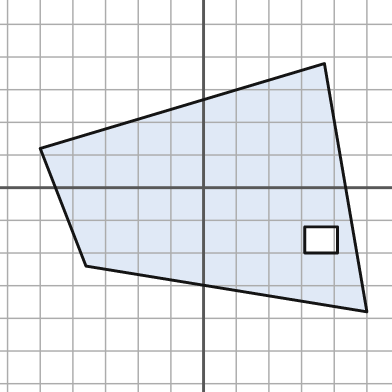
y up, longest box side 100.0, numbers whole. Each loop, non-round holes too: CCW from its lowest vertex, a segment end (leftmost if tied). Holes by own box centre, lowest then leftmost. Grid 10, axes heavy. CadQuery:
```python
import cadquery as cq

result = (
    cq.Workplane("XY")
    .moveTo(50.0, -38.0)
    .lineTo(37.0, 38.0)
    .lineTo(-50.0, 12.0)
    .lineTo(-36.0, -24.0)
    .close()
    .moveTo(31.0, -20.0)
    .lineTo(41.0, -20.0)
    .lineTo(41.0, -12.0)
    .lineTo(31.0, -12.0)
    .close()
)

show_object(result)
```